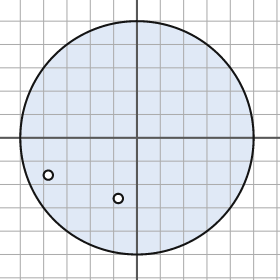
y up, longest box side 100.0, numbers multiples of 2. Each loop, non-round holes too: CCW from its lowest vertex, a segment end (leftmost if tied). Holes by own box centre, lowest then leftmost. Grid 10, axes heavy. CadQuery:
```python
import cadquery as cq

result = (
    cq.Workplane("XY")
    .moveTo(0.0, 0.0)
    .circle(50.0)
    .moveTo(-8.0, -26.0)
    .circle(2.0)
    .moveTo(-38.0, -16.0)
    .circle(2.0)
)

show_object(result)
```